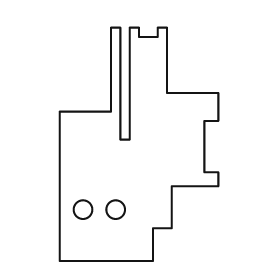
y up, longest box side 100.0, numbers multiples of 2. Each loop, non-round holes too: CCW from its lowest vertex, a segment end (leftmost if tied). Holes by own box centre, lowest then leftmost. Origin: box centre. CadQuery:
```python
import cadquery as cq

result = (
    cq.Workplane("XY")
    .moveTo(-34.0, -50.0)
    .lineTo(6.0, -50.0)
    .lineTo(6.0, -36.0)
    .lineTo(14.0, -36.0)
    .lineTo(14.0, -18.0)
    .lineTo(34.0, -18.0)
    .lineTo(34.0, -12.0)
    .lineTo(28.0, -12.0)
    .lineTo(28.0, 10.0)
    .lineTo(34.0, 10.0)
    .lineTo(34.0, 22.0)
    .lineTo(12.0, 22.0)
    .lineTo(12.0, 50.0)
    .lineTo(8.0, 50.0)
    .lineTo(8.0, 46.0)
    .lineTo(0.0, 46.0)
    .lineTo(0.0, 50.0)
    .lineTo(-4.0, 50.0)
    .lineTo(-4.0, 2.0)
    .lineTo(-8.0, 2.0)
    .lineTo(-8.0, 50.0)
    .lineTo(-12.0, 50.0)
    .lineTo(-12.0, 14.0)
    .lineTo(-34.0, 14.0)
    .close()
    .moveTo(-24.0, -28.0)
    .circle(4.0)
    .moveTo(-10.0, -28.0)
    .circle(4.0)
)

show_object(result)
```